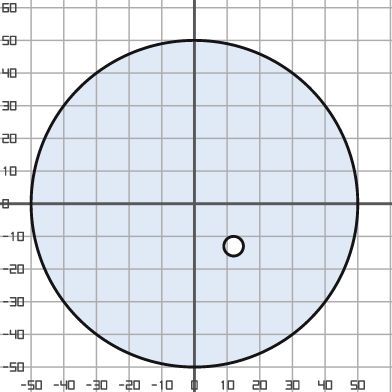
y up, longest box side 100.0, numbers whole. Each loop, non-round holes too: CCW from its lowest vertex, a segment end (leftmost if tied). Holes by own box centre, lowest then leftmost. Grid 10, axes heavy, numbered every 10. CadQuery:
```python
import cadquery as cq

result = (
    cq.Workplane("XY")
    .moveTo(0.0, 0.0)
    .circle(50.0)
    .moveTo(12.0, -13.0)
    .circle(3.0)
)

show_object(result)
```